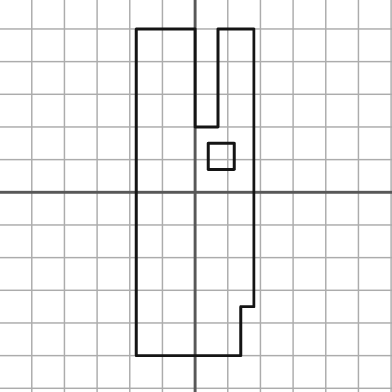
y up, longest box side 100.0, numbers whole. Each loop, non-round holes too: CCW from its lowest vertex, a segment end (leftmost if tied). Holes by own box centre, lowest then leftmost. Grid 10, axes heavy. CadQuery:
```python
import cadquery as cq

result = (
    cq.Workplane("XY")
    .moveTo(-18.0, -50.0)
    .lineTo(14.0, -50.0)
    .lineTo(14.0, -35.0)
    .lineTo(18.0, -35.0)
    .lineTo(18.0, 50.0)
    .lineTo(7.0, 50.0)
    .lineTo(7.0, 20.0)
    .lineTo(0.0, 20.0)
    .lineTo(0.0, 50.0)
    .lineTo(-18.0, 50.0)
    .close()
    .moveTo(4.0, 7.0)
    .lineTo(12.0, 7.0)
    .lineTo(12.0, 15.0)
    .lineTo(4.0, 15.0)
    .close()
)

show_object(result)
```